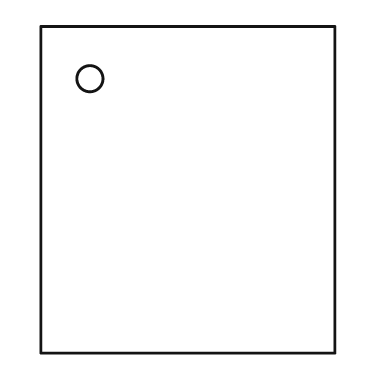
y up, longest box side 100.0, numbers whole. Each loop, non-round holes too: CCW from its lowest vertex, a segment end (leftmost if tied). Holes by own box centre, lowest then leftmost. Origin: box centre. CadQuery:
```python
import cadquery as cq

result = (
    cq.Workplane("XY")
    .moveTo(-45.0, -50.0)
    .lineTo(45.0, -50.0)
    .lineTo(45.0, 50.0)
    .lineTo(-45.0, 50.0)
    .close()
    .moveTo(-30.0, 34.0)
    .circle(4.0)
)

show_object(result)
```